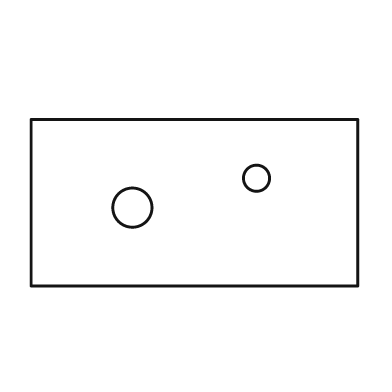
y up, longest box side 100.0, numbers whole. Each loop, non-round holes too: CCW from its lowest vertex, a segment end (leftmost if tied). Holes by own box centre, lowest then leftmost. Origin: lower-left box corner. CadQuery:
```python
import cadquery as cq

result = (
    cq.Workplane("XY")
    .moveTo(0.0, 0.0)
    .lineTo(100.0, 0.0)
    .lineTo(100.0, 51.0)
    .lineTo(0.0, 51.0)
    .close()
    .moveTo(31.0, 24.0)
    .circle(6.0)
    .moveTo(69.0, 33.0)
    .circle(4.0)
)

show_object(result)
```